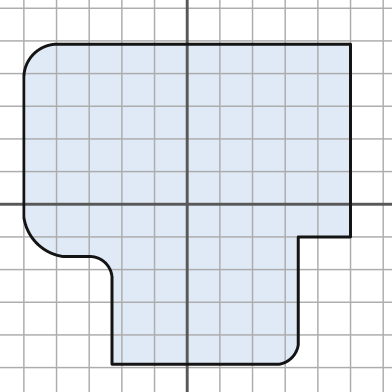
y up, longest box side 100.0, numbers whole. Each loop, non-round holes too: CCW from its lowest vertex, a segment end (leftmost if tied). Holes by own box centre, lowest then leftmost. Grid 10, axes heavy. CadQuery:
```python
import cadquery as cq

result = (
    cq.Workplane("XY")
    .moveTo(-23.0, -49.0)
    .lineTo(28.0, -49.0)
    .threePointArc((32.0, -47.0), (34.0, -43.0))
    .lineTo(34.0, -10.0)
    .lineTo(50.0, -10.0)
    .lineTo(50.0, 49.0)
    .lineTo(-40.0, 49.0)
    .threePointArc((-47.0, 46.0), (-50.0, 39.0))
    .lineTo(-50.0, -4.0)
    .threePointArc((-46.0, -12.0), (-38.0, -16.0))
    .lineTo(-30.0, -16.0)
    .threePointArc((-25.0, -18.0), (-23.0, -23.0))
    .close()
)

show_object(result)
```